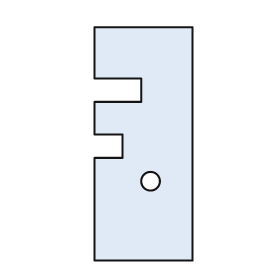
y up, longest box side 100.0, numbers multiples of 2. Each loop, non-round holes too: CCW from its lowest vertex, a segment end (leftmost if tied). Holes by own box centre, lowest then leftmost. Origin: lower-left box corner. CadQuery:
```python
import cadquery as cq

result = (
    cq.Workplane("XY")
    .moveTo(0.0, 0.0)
    .lineTo(42.0, 0.0)
    .lineTo(42.0, 100.0)
    .lineTo(0.0, 100.0)
    .lineTo(0.0, 78.0)
    .lineTo(20.0, 78.0)
    .lineTo(20.0, 68.0)
    .lineTo(0.0, 68.0)
    .lineTo(0.0, 54.0)
    .lineTo(12.0, 54.0)
    .lineTo(12.0, 44.0)
    .lineTo(0.0, 44.0)
    .close()
    .moveTo(24.0, 34.0)
    .circle(4.0)
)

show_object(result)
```